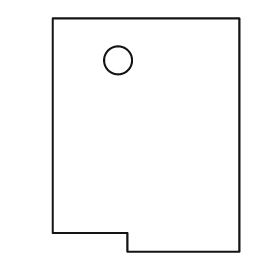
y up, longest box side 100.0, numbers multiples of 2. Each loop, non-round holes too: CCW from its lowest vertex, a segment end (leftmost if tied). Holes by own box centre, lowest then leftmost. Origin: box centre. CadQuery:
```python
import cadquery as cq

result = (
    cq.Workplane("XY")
    .moveTo(-8.0, -50.0)
    .lineTo(40.0, -50.0)
    .lineTo(40.0, 50.0)
    .lineTo(-40.0, 50.0)
    .lineTo(-40.0, -42.0)
    .lineTo(-8.0, -42.0)
    .close()
    .moveTo(-12.0, 32.0)
    .circle(6.0)
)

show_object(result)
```